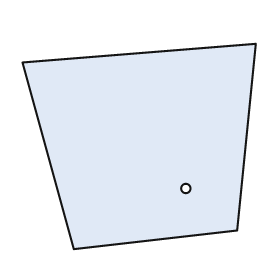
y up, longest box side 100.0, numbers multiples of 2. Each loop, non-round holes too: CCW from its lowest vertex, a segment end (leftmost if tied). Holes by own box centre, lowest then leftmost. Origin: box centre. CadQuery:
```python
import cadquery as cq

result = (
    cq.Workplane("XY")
    .moveTo(-28.0, -44.0)
    .lineTo(42.0, -36.0)
    .lineTo(50.0, 44.0)
    .lineTo(-50.0, 36.0)
    .close()
    .moveTo(20.0, -18.0)
    .circle(2.0)
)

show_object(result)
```